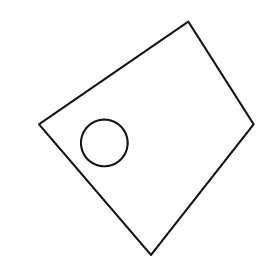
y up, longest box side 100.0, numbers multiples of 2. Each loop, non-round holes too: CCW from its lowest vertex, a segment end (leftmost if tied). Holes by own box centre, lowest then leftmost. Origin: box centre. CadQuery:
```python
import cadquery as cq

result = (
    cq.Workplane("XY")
    .moveTo(2.0, -50.0)
    .lineTo(46.0, 6.0)
    .lineTo(18.0, 50.0)
    .lineTo(-46.0, 6.0)
    .close()
    .moveTo(-18.0, -2.0)
    .circle(10.0)
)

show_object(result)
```